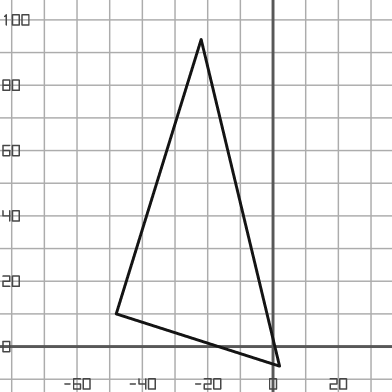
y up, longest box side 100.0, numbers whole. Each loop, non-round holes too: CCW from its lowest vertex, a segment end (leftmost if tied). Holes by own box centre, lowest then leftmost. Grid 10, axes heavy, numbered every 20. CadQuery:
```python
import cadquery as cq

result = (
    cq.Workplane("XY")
    .moveTo(2.0, -6.0)
    .lineTo(-22.0, 94.0)
    .lineTo(-48.0, 10.0)
    .close()
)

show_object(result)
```